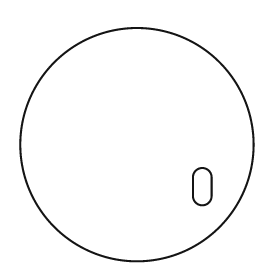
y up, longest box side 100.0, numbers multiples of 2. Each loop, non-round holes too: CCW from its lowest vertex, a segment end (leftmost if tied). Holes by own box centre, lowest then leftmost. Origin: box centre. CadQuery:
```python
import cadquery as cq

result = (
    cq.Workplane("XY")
    .moveTo(0.0, 0.0)
    .circle(50.0)
    .moveTo(24.0, -22.0)
    .threePointArc((28.0, -26.0), (32.0, -22.0))
    .lineTo(32.0, -14.0)
    .threePointArc((28.0, -10.0), (24.0, -14.0))
    .close()
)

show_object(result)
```